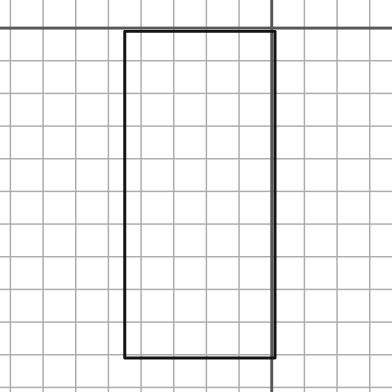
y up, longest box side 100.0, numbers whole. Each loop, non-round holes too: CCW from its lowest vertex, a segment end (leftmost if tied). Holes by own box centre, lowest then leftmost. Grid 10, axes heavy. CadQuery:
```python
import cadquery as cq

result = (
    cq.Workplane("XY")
    .moveTo(-45.0, -101.0)
    .lineTo(1.0, -101.0)
    .lineTo(1.0, -1.0)
    .lineTo(-45.0, -1.0)
    .close()
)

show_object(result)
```